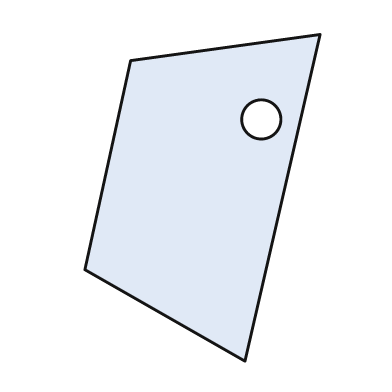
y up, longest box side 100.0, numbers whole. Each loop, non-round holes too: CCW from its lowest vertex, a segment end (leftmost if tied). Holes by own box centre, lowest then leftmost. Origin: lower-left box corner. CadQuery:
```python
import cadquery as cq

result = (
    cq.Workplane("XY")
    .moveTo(49.0, 0.0)
    .lineTo(72.0, 100.0)
    .lineTo(14.0, 92.0)
    .lineTo(0.0, 28.0)
    .close()
    .moveTo(54.0, 74.0)
    .circle(6.0)
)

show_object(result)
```